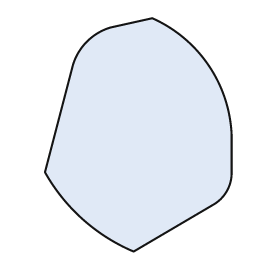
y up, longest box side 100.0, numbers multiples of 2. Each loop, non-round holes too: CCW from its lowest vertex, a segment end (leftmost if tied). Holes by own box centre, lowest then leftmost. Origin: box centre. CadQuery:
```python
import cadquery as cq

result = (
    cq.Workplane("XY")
    .moveTo(-2.0, -50.0)
    .lineTo(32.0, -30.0)
    .threePointArc((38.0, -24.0), (40.0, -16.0))
    .lineTo(40.0, 0.0)
    .threePointArc((30.0, 30.0), (6.0, 50.0))
    .lineTo(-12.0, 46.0)
    .threePointArc((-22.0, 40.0), (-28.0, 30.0))
    .lineTo(-40.0, -16.0)
    .threePointArc((-24.0, -36.0), (-2.0, -50.0))
    .close()
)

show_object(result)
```